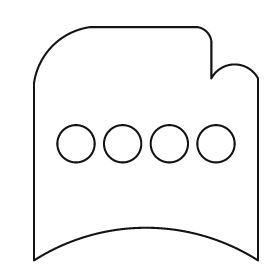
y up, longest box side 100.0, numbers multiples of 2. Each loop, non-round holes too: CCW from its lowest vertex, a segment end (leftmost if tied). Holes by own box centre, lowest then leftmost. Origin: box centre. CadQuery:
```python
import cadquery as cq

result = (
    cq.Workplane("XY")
    .moveTo(-48.0, -50.0)
    .threePointArc((0.0, -36.0), (48.0, -50.0))
    .lineTo(48.0, 28.0)
    .threePointArc((38.0, 34.0), (28.0, 28.0))
    .lineTo(28.0, 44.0)
    .threePointArc((26.0, 48.0), (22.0, 50.0))
    .lineTo(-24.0, 50.0)
    .threePointArc((-40.0, 42.0), (-48.0, 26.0))
    .close()
    .moveTo(-30.0, 0.0)
    .circle(8.0)
    .moveTo(-10.0, 0.0)
    .circle(8.0)
    .moveTo(10.0, 0.0)
    .circle(8.0)
    .moveTo(30.0, 0.0)
    .circle(8.0)
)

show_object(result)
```